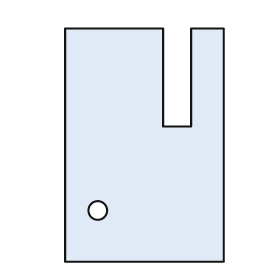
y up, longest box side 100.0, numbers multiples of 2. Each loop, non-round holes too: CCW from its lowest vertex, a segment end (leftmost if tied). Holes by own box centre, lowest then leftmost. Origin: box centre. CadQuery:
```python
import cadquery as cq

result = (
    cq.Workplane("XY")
    .moveTo(-34.0, -50.0)
    .lineTo(34.0, -50.0)
    .lineTo(34.0, 50.0)
    .lineTo(20.0, 50.0)
    .lineTo(20.0, 8.0)
    .lineTo(8.0, 8.0)
    .lineTo(8.0, 50.0)
    .lineTo(-34.0, 50.0)
    .close()
    .moveTo(-20.0, -28.0)
    .circle(4.0)
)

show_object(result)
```